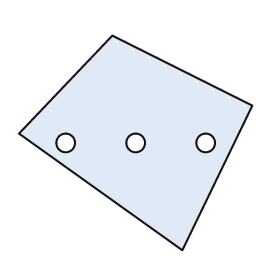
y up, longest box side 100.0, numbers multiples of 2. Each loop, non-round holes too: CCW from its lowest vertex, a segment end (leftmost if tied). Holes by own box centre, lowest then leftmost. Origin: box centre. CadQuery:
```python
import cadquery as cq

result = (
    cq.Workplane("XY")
    .moveTo(20.0, -46.0)
    .lineTo(50.0, 16.0)
    .lineTo(-10.0, 46.0)
    .lineTo(-50.0, 4.0)
    .close()
    .moveTo(-30.0, 0.0)
    .circle(4.0)
    .moveTo(0.0, 0.0)
    .circle(4.0)
    .moveTo(30.0, 0.0)
    .circle(4.0)
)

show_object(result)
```